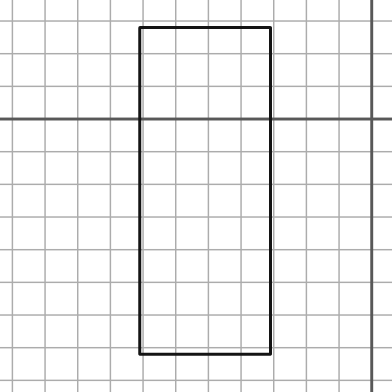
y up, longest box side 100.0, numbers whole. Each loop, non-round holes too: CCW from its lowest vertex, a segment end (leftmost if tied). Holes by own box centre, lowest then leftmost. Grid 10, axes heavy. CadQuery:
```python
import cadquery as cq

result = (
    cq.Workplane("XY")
    .moveTo(-71.0, -72.0)
    .lineTo(-31.0, -72.0)
    .lineTo(-31.0, 28.0)
    .lineTo(-71.0, 28.0)
    .close()
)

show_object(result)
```